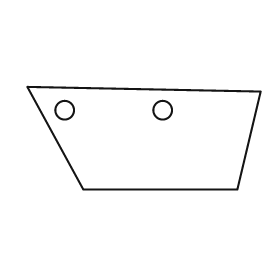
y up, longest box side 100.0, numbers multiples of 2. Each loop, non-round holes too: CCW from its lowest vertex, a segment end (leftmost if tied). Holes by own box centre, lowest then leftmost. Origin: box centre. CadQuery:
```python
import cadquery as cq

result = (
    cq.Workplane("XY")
    .moveTo(-26.0, -22.0)
    .lineTo(40.0, -22.0)
    .lineTo(50.0, 20.0)
    .lineTo(-50.0, 22.0)
    .close()
    .moveTo(-34.0, 12.0)
    .circle(4.0)
    .moveTo(8.0, 12.0)
    .circle(4.0)
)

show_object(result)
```